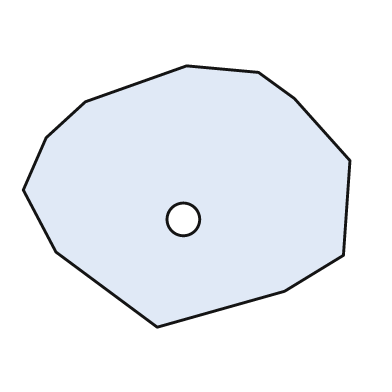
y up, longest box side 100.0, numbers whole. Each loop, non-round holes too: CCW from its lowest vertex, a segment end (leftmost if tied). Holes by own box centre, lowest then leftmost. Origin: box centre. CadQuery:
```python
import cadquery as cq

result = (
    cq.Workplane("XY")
    .moveTo(-9.0, -40.0)
    .lineTo(30.0, -29.0)
    .lineTo(48.0, -18.0)
    .lineTo(50.0, 11.0)
    .lineTo(33.0, 30.0)
    .lineTo(22.0, 38.0)
    .lineTo(0.0, 40.0)
    .lineTo(-31.0, 29.0)
    .lineTo(-43.0, 18.0)
    .lineTo(-50.0, 2.0)
    .lineTo(-40.0, -17.0)
    .close()
    .moveTo(-1.0, -7.0)
    .circle(5.0)
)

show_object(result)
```